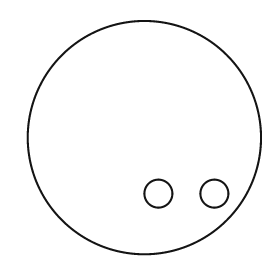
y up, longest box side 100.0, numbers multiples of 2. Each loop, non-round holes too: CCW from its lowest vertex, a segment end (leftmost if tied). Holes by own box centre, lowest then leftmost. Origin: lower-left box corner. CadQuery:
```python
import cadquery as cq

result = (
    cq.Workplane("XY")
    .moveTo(50.0, 50.0)
    .circle(50.0)
    .moveTo(56.0, 26.0)
    .circle(6.0)
    .moveTo(80.0, 26.0)
    .circle(6.0)
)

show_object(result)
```